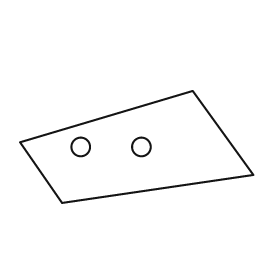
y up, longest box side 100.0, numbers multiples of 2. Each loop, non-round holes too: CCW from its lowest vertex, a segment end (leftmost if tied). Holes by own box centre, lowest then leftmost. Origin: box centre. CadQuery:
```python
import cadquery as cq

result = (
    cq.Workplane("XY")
    .moveTo(-32.0, -24.0)
    .lineTo(50.0, -12.0)
    .lineTo(24.0, 24.0)
    .lineTo(-50.0, 2.0)
    .close()
    .moveTo(-24.0, 0.0)
    .circle(4.0)
    .moveTo(2.0, 0.0)
    .circle(4.0)
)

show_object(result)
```